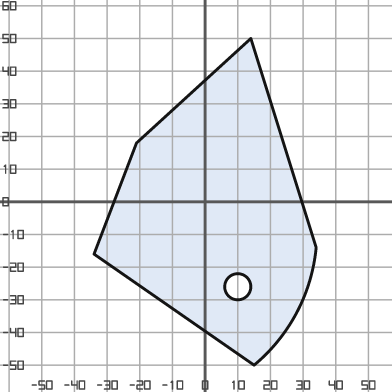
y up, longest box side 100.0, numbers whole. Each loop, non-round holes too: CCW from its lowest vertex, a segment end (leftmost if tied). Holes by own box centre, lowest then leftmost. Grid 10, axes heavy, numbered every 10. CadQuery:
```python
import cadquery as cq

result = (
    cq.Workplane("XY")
    .moveTo(15.0, -50.0)
    .threePointArc((28.0, -34.0), (34.0, -14.0))
    .lineTo(14.0, 50.0)
    .lineTo(-21.0, 18.0)
    .lineTo(-34.0, -16.0)
    .close()
    .moveTo(10.0, -26.0)
    .circle(4.0)
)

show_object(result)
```